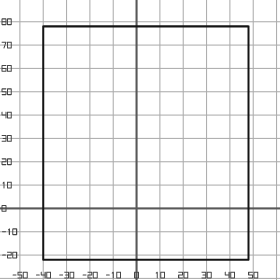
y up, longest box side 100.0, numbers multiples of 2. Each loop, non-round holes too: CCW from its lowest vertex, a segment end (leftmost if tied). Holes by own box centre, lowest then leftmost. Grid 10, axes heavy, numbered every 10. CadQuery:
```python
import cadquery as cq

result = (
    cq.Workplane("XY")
    .moveTo(-40.0, -22.0)
    .lineTo(48.0, -22.0)
    .lineTo(48.0, 78.0)
    .lineTo(-40.0, 78.0)
    .close()
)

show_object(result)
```